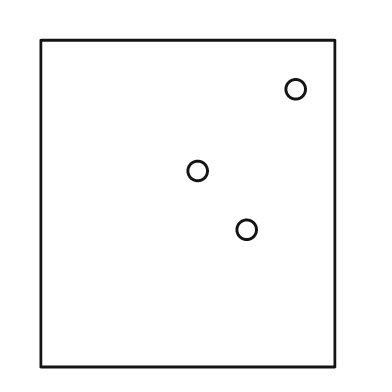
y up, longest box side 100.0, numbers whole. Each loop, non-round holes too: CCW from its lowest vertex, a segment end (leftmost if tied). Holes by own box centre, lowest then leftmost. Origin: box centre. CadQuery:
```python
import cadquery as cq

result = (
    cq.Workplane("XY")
    .moveTo(-45.0, -50.0)
    .lineTo(45.0, -50.0)
    .lineTo(45.0, 50.0)
    .lineTo(-45.0, 50.0)
    .close()
    .moveTo(18.0, -8.0)
    .circle(3.0)
    .moveTo(3.0, 10.0)
    .circle(3.0)
    .moveTo(33.0, 35.0)
    .circle(3.0)
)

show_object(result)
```